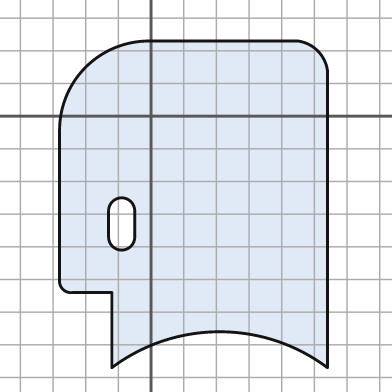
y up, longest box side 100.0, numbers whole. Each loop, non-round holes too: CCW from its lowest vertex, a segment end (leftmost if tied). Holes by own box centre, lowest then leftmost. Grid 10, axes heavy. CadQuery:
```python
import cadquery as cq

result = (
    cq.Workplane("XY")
    .moveTo(-12.0, -77.0)
    .threePointArc((21.0, -66.0), (54.0, -77.0))
    .lineTo(54.0, 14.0)
    .threePointArc((51.0, 20.0), (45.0, 23.0))
    .lineTo(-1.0, 23.0)
    .threePointArc((-20.0, 15.0), (-28.0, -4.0))
    .lineTo(-28.0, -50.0)
    .threePointArc((-27.0, -53.0), (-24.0, -54.0))
    .lineTo(-12.0, -54.0)
    .close()
    .moveTo(-13.0, -37.0)
    .threePointArc((-9.0, -41.0), (-5.0, -37.0))
    .lineTo(-5.0, -29.0)
    .threePointArc((-9.0, -25.0), (-13.0, -29.0))
    .close()
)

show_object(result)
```